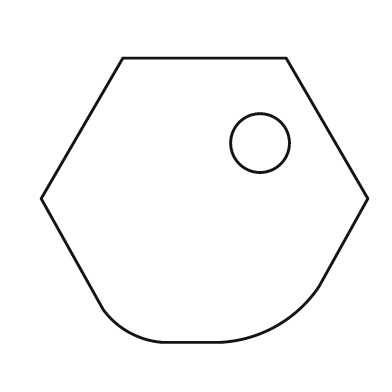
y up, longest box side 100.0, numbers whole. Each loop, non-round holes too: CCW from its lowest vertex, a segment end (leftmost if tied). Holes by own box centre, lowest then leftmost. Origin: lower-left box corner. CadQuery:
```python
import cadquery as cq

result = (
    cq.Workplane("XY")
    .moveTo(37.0, 0.0)
    .lineTo(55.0, 0.0)
    .threePointArc((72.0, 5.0), (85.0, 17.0))
    .lineTo(100.0, 44.0)
    .lineTo(75.0, 87.0)
    .lineTo(25.0, 87.0)
    .lineTo(0.0, 44.0)
    .lineTo(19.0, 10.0)
    .threePointArc((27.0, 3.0), (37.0, 0.0))
    .close()
    .moveTo(67.0, 61.0)
    .circle(9.0)
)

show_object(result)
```